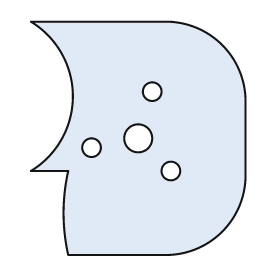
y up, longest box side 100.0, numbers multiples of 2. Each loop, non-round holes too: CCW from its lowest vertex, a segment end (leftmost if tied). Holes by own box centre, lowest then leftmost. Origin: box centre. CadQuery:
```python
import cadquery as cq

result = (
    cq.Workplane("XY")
    .moveTo(-30.0, -50.0)
    .lineTo(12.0, -50.0)
    .threePointArc((36.0, -40.0), (46.0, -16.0))
    .lineTo(46.0, 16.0)
    .threePointArc((36.0, 40.0), (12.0, 50.0))
    .lineTo(-46.0, 50.0)
    .threePointArc((-28.0, 18.0), (-46.0, -14.0))
    .lineTo(-30.0, -14.0)
    .threePointArc((-32.0, -32.0), (-30.0, -50.0))
    .close()
    .moveTo(14.0, -14.0)
    .circle(4.0)
    .moveTo(-20.0, -4.0)
    .circle(4.0)
    .moveTo(0.0, 0.0)
    .circle(6.0)
    .moveTo(6.0, 20.0)
    .circle(4.0)
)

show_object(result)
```